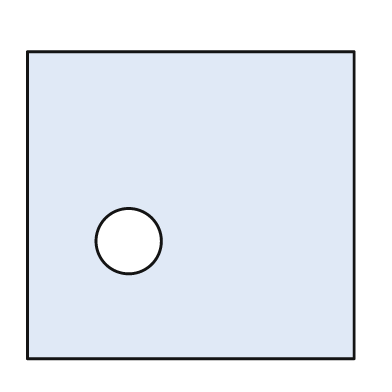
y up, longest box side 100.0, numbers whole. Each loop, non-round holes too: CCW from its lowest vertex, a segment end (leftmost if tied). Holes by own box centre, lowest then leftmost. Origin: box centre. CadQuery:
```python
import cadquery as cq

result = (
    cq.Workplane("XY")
    .moveTo(-50.0, -47.0)
    .lineTo(50.0, -47.0)
    .lineTo(50.0, 47.0)
    .lineTo(-50.0, 47.0)
    .close()
    .moveTo(-19.0, -11.0)
    .circle(10.0)
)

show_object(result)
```